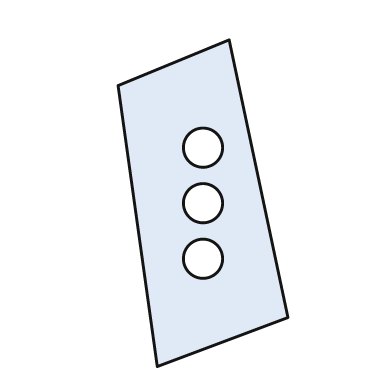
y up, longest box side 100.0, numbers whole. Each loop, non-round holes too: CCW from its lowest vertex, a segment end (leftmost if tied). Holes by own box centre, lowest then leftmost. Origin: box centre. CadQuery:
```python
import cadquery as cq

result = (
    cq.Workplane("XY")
    .moveTo(-14.0, -50.0)
    .lineTo(26.0, -35.0)
    .lineTo(8.0, 50.0)
    .lineTo(-26.0, 36.0)
    .close()
    .moveTo(0.0, -17.0)
    .circle(6.0)
    .moveTo(0.0, 0.0)
    .circle(6.0)
    .moveTo(0.0, 17.0)
    .circle(6.0)
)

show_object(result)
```